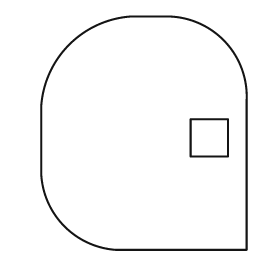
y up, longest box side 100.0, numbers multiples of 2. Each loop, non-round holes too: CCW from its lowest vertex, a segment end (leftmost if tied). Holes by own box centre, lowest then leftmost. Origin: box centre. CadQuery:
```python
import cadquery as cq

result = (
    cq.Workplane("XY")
    .moveTo(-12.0, -50.0)
    .lineTo(44.0, -50.0)
    .lineTo(44.0, 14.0)
    .threePointArc((34.0, 40.0), (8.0, 50.0))
    .lineTo(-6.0, 50.0)
    .threePointArc((-32.0, 38.0), (-44.0, 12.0))
    .lineTo(-44.0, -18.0)
    .threePointArc((-34.0, -40.0), (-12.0, -50.0))
    .close()
    .moveTo(20.0, -10.0)
    .lineTo(36.0, -10.0)
    .lineTo(36.0, 6.0)
    .lineTo(20.0, 6.0)
    .close()
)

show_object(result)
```